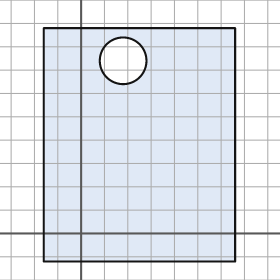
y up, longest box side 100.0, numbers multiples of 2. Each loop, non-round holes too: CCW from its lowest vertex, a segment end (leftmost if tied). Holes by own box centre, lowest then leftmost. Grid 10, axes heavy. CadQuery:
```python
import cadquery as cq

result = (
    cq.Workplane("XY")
    .moveTo(-16.0, -12.0)
    .lineTo(66.0, -12.0)
    .lineTo(66.0, 88.0)
    .lineTo(-16.0, 88.0)
    .close()
    .moveTo(18.0, 74.0)
    .circle(10.0)
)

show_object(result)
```